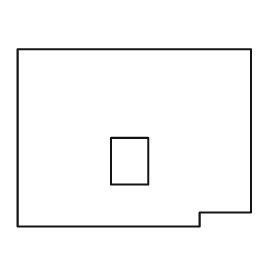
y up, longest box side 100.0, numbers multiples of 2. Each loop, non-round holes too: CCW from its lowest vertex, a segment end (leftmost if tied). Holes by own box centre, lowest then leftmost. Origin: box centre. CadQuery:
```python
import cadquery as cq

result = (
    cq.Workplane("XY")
    .moveTo(-50.0, -38.0)
    .lineTo(28.0, -38.0)
    .lineTo(28.0, -32.0)
    .lineTo(50.0, -32.0)
    .lineTo(50.0, 38.0)
    .lineTo(-50.0, 38.0)
    .close()
    .moveTo(-10.0, -20.0)
    .lineTo(6.0, -20.0)
    .lineTo(6.0, 0.0)
    .lineTo(-10.0, 0.0)
    .close()
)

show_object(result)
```